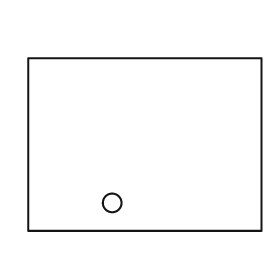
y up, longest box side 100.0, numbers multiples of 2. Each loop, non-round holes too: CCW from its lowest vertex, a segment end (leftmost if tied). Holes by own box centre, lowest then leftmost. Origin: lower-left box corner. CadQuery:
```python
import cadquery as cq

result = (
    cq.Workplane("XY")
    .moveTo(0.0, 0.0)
    .lineTo(100.0, 0.0)
    .lineTo(100.0, 74.0)
    .lineTo(0.0, 74.0)
    .close()
    .moveTo(36.0, 12.0)
    .circle(4.0)
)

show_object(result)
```